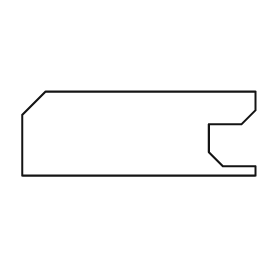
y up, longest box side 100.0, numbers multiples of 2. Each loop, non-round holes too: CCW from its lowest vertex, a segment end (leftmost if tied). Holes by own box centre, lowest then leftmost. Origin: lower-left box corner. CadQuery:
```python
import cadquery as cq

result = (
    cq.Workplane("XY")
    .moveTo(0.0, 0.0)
    .lineTo(100.0, 0.0)
    .lineTo(100.0, 4.0)
    .lineTo(86.0, 4.0)
    .lineTo(80.0, 10.0)
    .lineTo(80.0, 22.0)
    .lineTo(94.0, 22.0)
    .lineTo(100.0, 28.0)
    .lineTo(100.0, 36.0)
    .lineTo(10.0, 36.0)
    .lineTo(0.0, 26.0)
    .close()
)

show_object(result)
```